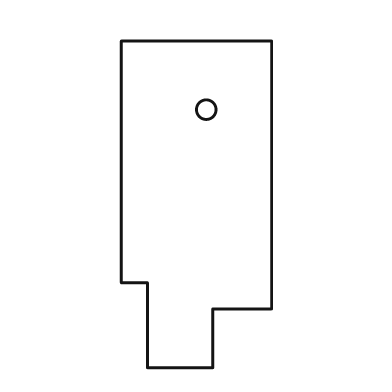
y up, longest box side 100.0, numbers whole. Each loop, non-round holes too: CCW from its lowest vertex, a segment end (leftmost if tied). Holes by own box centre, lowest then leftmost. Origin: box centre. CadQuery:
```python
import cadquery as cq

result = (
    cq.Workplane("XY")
    .moveTo(-15.0, -50.0)
    .lineTo(5.0, -50.0)
    .lineTo(5.0, -32.0)
    .lineTo(23.0, -32.0)
    .lineTo(23.0, 50.0)
    .lineTo(-23.0, 50.0)
    .lineTo(-23.0, -24.0)
    .lineTo(-15.0, -24.0)
    .close()
    .moveTo(3.0, 29.0)
    .circle(3.0)
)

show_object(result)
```